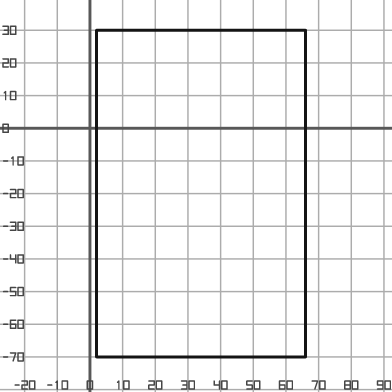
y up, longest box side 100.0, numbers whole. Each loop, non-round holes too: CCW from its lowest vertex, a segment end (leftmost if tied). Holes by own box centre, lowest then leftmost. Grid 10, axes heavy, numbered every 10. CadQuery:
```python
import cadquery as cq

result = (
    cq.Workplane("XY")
    .moveTo(2.0, -70.0)
    .lineTo(66.0, -70.0)
    .lineTo(66.0, 30.0)
    .lineTo(2.0, 30.0)
    .close()
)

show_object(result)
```